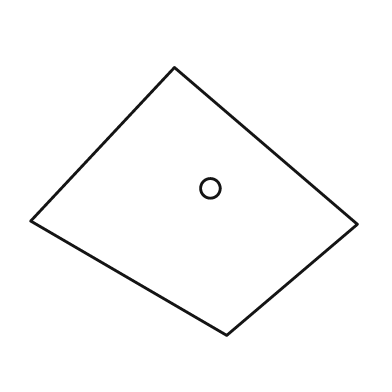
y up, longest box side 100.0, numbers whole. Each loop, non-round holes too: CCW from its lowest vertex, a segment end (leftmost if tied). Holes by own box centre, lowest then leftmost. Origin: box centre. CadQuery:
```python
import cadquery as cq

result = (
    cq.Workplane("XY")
    .moveTo(10.0, -41.0)
    .lineTo(50.0, -7.0)
    .lineTo(-6.0, 41.0)
    .lineTo(-50.0, -6.0)
    .close()
    .moveTo(5.0, 4.0)
    .circle(3.0)
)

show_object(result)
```